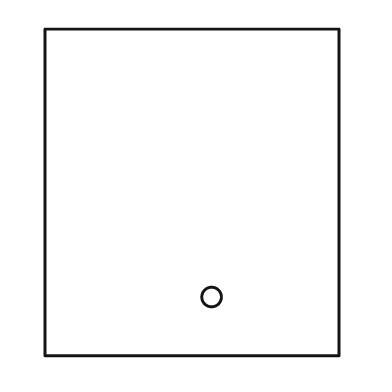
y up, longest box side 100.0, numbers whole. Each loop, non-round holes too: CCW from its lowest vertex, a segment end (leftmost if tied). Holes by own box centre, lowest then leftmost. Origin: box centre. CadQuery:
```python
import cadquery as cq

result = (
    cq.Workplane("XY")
    .moveTo(-45.0, -50.0)
    .lineTo(45.0, -50.0)
    .lineTo(45.0, 50.0)
    .lineTo(-45.0, 50.0)
    .close()
    .moveTo(6.0, -32.0)
    .circle(3.0)
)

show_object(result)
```